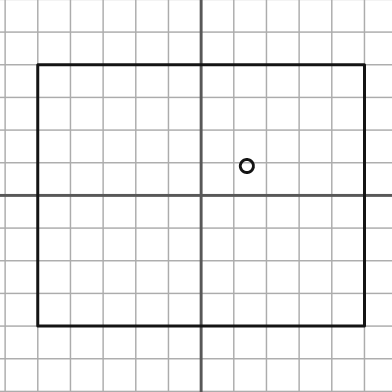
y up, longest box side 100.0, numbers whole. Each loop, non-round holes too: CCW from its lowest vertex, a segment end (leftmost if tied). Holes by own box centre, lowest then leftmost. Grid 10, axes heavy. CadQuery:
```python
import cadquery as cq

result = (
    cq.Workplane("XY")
    .moveTo(-50.0, -40.0)
    .lineTo(50.0, -40.0)
    .lineTo(50.0, 40.0)
    .lineTo(-50.0, 40.0)
    .close()
    .moveTo(14.0, 9.0)
    .circle(2.0)
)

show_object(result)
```